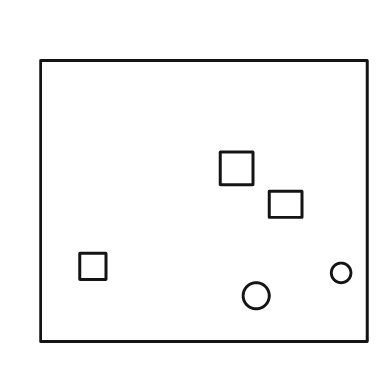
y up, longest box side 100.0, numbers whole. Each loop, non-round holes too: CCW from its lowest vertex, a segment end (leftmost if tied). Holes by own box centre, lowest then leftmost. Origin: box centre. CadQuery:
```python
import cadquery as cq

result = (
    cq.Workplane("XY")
    .moveTo(-50.0, -43.0)
    .lineTo(50.0, -43.0)
    .lineTo(50.0, 43.0)
    .lineTo(-50.0, 43.0)
    .close()
    .moveTo(16.0, -29.0)
    .circle(4.0)
    .moveTo(42.0, -22.0)
    .circle(3.0)
    .moveTo(-38.0, -24.0)
    .lineTo(-30.0, -24.0)
    .lineTo(-30.0, -16.0)
    .lineTo(-38.0, -16.0)
    .close()
    .moveTo(20.0, -5.0)
    .lineTo(30.0, -5.0)
    .lineTo(30.0, 3.0)
    .lineTo(20.0, 3.0)
    .close()
    .moveTo(5.0, 5.0)
    .lineTo(15.0, 5.0)
    .lineTo(15.0, 15.0)
    .lineTo(5.0, 15.0)
    .close()
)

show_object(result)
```